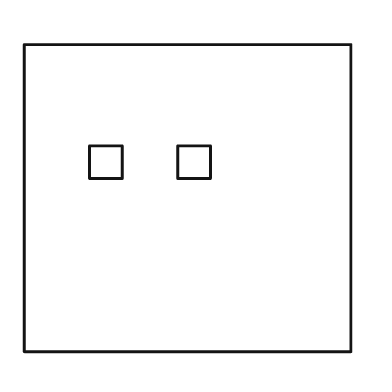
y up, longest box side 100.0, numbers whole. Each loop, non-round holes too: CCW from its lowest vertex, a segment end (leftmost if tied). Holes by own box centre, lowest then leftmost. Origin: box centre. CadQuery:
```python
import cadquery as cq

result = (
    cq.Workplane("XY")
    .moveTo(-50.0, -47.0)
    .lineTo(50.0, -47.0)
    .lineTo(50.0, 47.0)
    .lineTo(-50.0, 47.0)
    .close()
    .moveTo(-30.0, 6.0)
    .lineTo(-20.0, 6.0)
    .lineTo(-20.0, 16.0)
    .lineTo(-30.0, 16.0)
    .close()
    .moveTo(-3.0, 6.0)
    .lineTo(7.0, 6.0)
    .lineTo(7.0, 16.0)
    .lineTo(-3.0, 16.0)
    .close()
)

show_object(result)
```